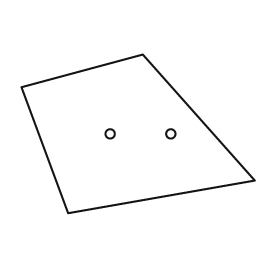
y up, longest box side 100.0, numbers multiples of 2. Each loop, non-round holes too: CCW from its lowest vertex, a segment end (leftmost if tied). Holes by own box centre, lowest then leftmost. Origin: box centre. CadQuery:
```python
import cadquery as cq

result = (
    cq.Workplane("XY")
    .moveTo(-30.0, -34.0)
    .lineTo(50.0, -20.0)
    .lineTo(2.0, 34.0)
    .lineTo(-50.0, 20.0)
    .close()
    .moveTo(-12.0, 0.0)
    .circle(2.0)
    .moveTo(14.0, 0.0)
    .circle(2.0)
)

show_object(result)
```